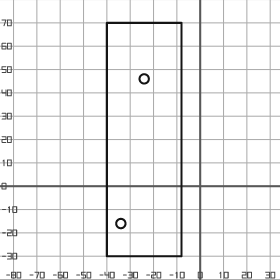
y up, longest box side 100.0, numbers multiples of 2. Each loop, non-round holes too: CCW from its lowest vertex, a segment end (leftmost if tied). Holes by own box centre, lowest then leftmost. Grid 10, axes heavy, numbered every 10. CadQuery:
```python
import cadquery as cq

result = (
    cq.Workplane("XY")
    .moveTo(-40.0, -30.0)
    .lineTo(-8.0, -30.0)
    .lineTo(-8.0, 70.0)
    .lineTo(-40.0, 70.0)
    .close()
    .moveTo(-34.0, -16.0)
    .circle(2.0)
    .moveTo(-24.0, 46.0)
    .circle(2.0)
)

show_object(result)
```